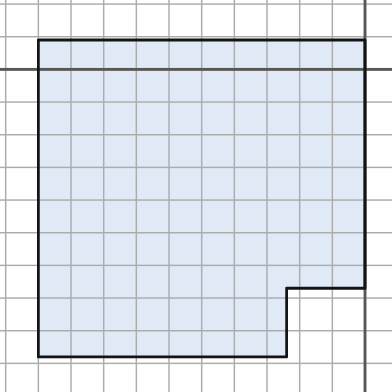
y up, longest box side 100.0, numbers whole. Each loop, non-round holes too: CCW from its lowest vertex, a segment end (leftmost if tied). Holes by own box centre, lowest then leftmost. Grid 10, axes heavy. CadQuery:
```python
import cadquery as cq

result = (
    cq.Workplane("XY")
    .moveTo(-100.0, -88.0)
    .lineTo(-24.0, -88.0)
    .lineTo(-24.0, -67.0)
    .lineTo(0.0, -67.0)
    .lineTo(0.0, 9.0)
    .lineTo(-100.0, 9.0)
    .close()
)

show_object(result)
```